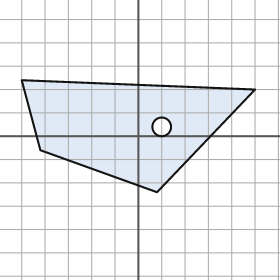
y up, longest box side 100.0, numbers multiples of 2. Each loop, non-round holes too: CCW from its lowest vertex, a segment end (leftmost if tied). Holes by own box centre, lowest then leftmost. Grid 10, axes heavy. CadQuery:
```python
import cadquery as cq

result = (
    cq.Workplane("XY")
    .moveTo(8.0, -24.0)
    .lineTo(50.0, 20.0)
    .lineTo(-50.0, 24.0)
    .lineTo(-42.0, -6.0)
    .close()
    .moveTo(10.0, 4.0)
    .circle(4.0)
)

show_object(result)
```